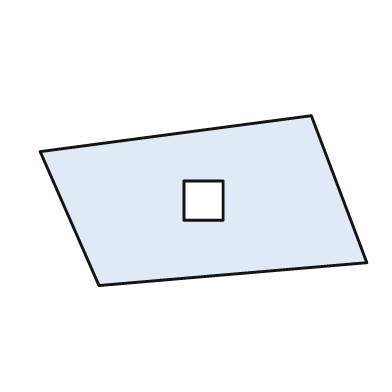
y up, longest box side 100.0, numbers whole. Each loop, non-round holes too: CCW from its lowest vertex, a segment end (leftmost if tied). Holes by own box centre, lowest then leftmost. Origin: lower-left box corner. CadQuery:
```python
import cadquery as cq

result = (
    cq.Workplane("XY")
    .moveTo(18.0, 0.0)
    .lineTo(100.0, 7.0)
    .lineTo(83.0, 52.0)
    .lineTo(0.0, 41.0)
    .close()
    .moveTo(44.0, 20.0)
    .lineTo(56.0, 20.0)
    .lineTo(56.0, 32.0)
    .lineTo(44.0, 32.0)
    .close()
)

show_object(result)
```